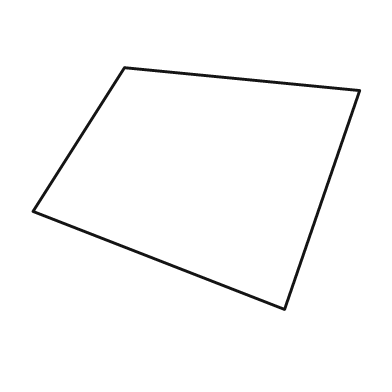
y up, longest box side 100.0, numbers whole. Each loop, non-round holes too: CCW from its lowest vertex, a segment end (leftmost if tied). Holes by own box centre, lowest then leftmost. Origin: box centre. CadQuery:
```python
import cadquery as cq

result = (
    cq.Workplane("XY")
    .moveTo(27.0, -37.0)
    .lineTo(50.0, 30.0)
    .lineTo(-22.0, 37.0)
    .lineTo(-50.0, -7.0)
    .close()
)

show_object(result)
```